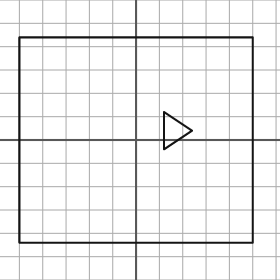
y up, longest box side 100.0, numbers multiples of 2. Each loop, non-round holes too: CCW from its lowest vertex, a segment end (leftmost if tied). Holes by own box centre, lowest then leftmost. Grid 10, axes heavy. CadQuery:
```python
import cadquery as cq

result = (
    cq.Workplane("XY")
    .moveTo(-50.0, -44.0)
    .lineTo(50.0, -44.0)
    .lineTo(50.0, 44.0)
    .lineTo(-50.0, 44.0)
    .close()
    .moveTo(12.0, -4.0)
    .lineTo(24.0, 4.0)
    .lineTo(12.0, 12.0)
    .close()
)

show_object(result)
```